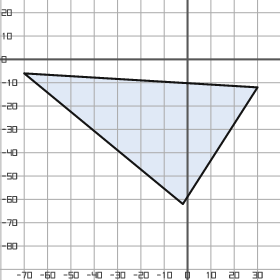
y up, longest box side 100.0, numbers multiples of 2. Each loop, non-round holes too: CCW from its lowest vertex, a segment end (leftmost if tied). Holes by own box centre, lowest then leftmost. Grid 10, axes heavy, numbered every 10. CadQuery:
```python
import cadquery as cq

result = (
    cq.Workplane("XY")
    .moveTo(-2.0, -62.0)
    .lineTo(30.0, -12.0)
    .lineTo(-70.0, -6.0)
    .close()
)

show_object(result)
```